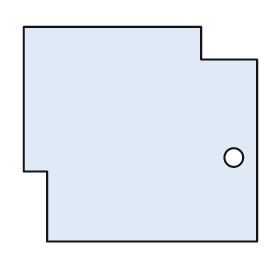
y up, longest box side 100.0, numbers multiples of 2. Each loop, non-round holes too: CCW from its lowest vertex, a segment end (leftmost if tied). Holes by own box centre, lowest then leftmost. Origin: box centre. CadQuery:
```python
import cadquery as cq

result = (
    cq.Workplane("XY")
    .moveTo(-40.0, -46.0)
    .lineTo(50.0, -46.0)
    .lineTo(50.0, 32.0)
    .lineTo(26.0, 32.0)
    .lineTo(26.0, 46.0)
    .lineTo(-50.0, 46.0)
    .lineTo(-50.0, -16.0)
    .lineTo(-40.0, -16.0)
    .close()
    .moveTo(40.0, -10.0)
    .circle(4.0)
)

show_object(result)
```